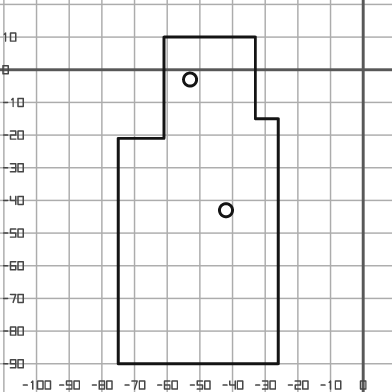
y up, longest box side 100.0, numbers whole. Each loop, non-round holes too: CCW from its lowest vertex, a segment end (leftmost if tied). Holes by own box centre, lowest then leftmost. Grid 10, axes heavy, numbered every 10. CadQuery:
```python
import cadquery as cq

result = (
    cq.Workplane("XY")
    .moveTo(-75.0, -90.0)
    .lineTo(-26.0, -90.0)
    .lineTo(-26.0, -15.0)
    .lineTo(-33.0, -15.0)
    .lineTo(-33.0, 10.0)
    .lineTo(-61.0, 10.0)
    .lineTo(-61.0, -21.0)
    .lineTo(-75.0, -21.0)
    .close()
    .moveTo(-42.0, -43.0)
    .circle(2.0)
    .moveTo(-53.0, -3.0)
    .circle(2.0)
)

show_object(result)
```